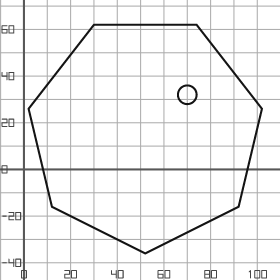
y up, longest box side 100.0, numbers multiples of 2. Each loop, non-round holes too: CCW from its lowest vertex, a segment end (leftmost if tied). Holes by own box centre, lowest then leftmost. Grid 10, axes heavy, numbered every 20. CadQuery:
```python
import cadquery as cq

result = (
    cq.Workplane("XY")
    .moveTo(52.0, -36.0)
    .lineTo(92.0, -16.0)
    .lineTo(102.0, 26.0)
    .lineTo(74.0, 62.0)
    .lineTo(30.0, 62.0)
    .lineTo(2.0, 26.0)
    .lineTo(12.0, -16.0)
    .close()
    .moveTo(70.0, 32.0)
    .circle(4.0)
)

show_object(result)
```